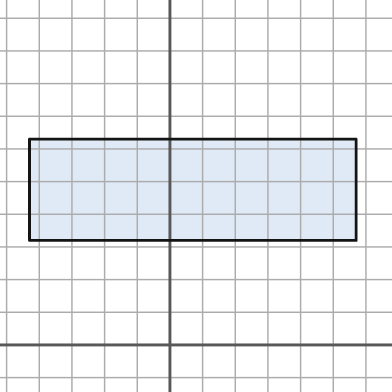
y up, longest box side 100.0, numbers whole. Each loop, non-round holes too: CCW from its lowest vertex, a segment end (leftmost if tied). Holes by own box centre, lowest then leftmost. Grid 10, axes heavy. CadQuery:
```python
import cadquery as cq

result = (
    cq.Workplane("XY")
    .moveTo(-43.0, 32.0)
    .lineTo(57.0, 32.0)
    .lineTo(57.0, 63.0)
    .lineTo(-43.0, 63.0)
    .close()
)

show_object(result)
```